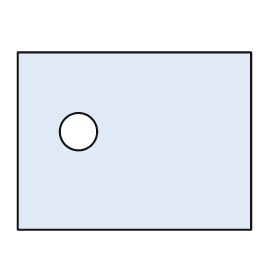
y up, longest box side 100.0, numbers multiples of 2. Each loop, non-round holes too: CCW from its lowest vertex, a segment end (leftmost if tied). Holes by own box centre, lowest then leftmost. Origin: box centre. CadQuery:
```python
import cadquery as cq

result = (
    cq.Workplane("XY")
    .moveTo(-50.0, -38.0)
    .lineTo(50.0, -38.0)
    .lineTo(50.0, 38.0)
    .lineTo(-50.0, 38.0)
    .close()
    .moveTo(-24.0, 4.0)
    .circle(8.0)
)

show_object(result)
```